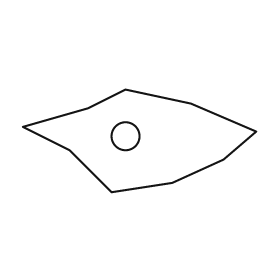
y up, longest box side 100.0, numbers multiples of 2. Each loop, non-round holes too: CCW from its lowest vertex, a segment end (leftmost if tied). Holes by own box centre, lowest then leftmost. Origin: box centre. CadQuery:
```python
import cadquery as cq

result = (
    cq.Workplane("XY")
    .moveTo(-12.0, -22.0)
    .lineTo(14.0, -18.0)
    .lineTo(36.0, -8.0)
    .lineTo(50.0, 4.0)
    .lineTo(22.0, 16.0)
    .lineTo(-6.0, 22.0)
    .lineTo(-22.0, 14.0)
    .lineTo(-50.0, 6.0)
    .lineTo(-30.0, -4.0)
    .close()
    .moveTo(-6.0, 2.0)
    .circle(6.0)
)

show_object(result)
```